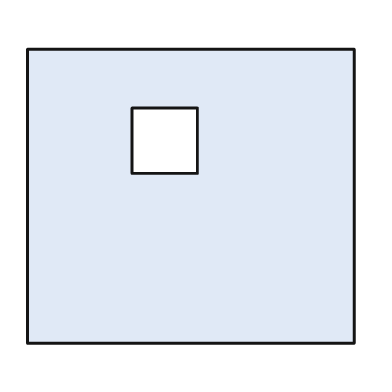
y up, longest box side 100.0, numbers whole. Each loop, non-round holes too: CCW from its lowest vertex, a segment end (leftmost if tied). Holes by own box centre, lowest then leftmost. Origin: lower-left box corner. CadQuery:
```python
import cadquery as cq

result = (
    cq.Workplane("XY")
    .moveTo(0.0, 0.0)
    .lineTo(100.0, 0.0)
    .lineTo(100.0, 90.0)
    .lineTo(0.0, 90.0)
    .close()
    .moveTo(32.0, 52.0)
    .lineTo(52.0, 52.0)
    .lineTo(52.0, 72.0)
    .lineTo(32.0, 72.0)
    .close()
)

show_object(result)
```